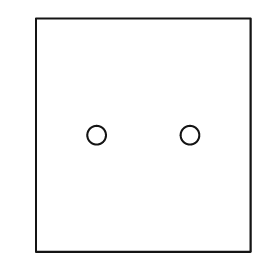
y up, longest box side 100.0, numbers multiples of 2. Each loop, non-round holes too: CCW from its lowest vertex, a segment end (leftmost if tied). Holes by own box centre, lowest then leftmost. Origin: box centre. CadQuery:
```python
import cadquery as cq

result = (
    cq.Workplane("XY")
    .moveTo(-46.0, -50.0)
    .lineTo(46.0, -50.0)
    .lineTo(46.0, 50.0)
    .lineTo(-46.0, 50.0)
    .close()
    .moveTo(-20.0, 0.0)
    .circle(4.0)
    .moveTo(20.0, 0.0)
    .circle(4.0)
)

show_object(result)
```